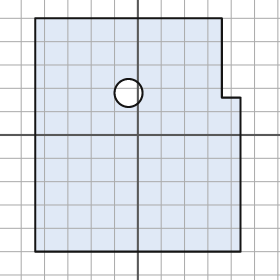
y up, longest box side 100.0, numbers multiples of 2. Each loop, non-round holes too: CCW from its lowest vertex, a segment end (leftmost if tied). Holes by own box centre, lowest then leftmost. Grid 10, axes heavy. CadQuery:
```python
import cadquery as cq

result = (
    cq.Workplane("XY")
    .moveTo(-44.0, -50.0)
    .lineTo(44.0, -50.0)
    .lineTo(44.0, 16.0)
    .lineTo(36.0, 16.0)
    .lineTo(36.0, 50.0)
    .lineTo(-44.0, 50.0)
    .close()
    .moveTo(-4.0, 18.0)
    .circle(6.0)
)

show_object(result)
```